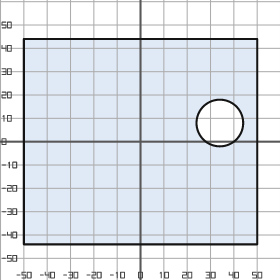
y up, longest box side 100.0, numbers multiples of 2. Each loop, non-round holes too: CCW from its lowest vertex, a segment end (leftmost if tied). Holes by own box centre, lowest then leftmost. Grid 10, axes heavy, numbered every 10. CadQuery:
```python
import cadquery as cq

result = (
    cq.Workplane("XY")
    .moveTo(-50.0, -44.0)
    .lineTo(50.0, -44.0)
    .lineTo(50.0, 44.0)
    .lineTo(-50.0, 44.0)
    .close()
    .moveTo(34.0, 8.0)
    .circle(10.0)
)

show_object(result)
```